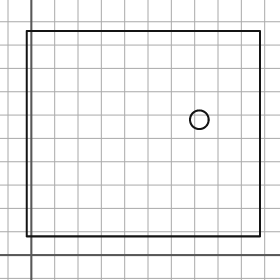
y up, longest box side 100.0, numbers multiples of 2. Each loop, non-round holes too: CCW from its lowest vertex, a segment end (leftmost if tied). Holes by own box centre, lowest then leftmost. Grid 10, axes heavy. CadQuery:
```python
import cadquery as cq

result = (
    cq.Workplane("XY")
    .moveTo(-2.0, 8.0)
    .lineTo(98.0, 8.0)
    .lineTo(98.0, 96.0)
    .lineTo(-2.0, 96.0)
    .close()
    .moveTo(72.0, 58.0)
    .circle(4.0)
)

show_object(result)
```